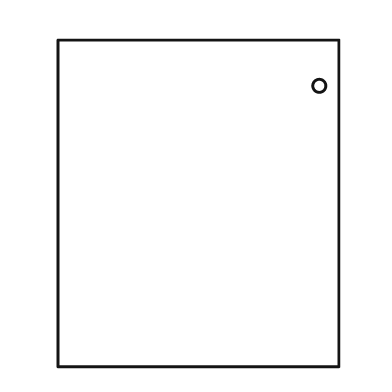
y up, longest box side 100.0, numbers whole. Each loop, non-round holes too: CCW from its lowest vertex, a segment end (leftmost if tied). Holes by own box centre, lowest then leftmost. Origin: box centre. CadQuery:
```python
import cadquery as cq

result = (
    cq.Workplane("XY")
    .moveTo(-43.0, -50.0)
    .lineTo(43.0, -50.0)
    .lineTo(43.0, 50.0)
    .lineTo(-43.0, 50.0)
    .close()
    .moveTo(37.0, 36.0)
    .circle(2.0)
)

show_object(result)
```